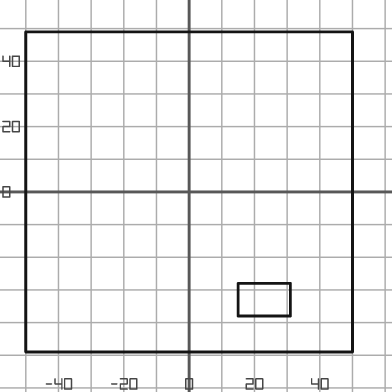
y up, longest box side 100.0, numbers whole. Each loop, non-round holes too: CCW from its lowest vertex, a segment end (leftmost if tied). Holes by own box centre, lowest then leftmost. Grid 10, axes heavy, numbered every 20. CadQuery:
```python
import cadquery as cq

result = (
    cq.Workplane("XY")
    .moveTo(-50.0, -49.0)
    .lineTo(50.0, -49.0)
    .lineTo(50.0, 49.0)
    .lineTo(-50.0, 49.0)
    .close()
    .moveTo(15.0, -38.0)
    .lineTo(31.0, -38.0)
    .lineTo(31.0, -28.0)
    .lineTo(15.0, -28.0)
    .close()
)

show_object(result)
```